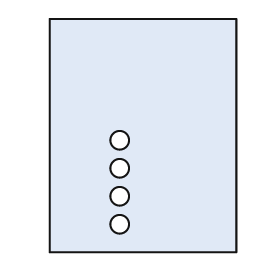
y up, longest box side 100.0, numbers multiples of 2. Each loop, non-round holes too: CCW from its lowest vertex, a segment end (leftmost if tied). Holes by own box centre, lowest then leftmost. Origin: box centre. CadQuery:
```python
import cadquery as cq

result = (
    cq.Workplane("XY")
    .moveTo(-40.0, -50.0)
    .lineTo(40.0, -50.0)
    .lineTo(40.0, 50.0)
    .lineTo(-40.0, 50.0)
    .close()
    .moveTo(-10.0, -38.0)
    .circle(4.0)
    .moveTo(-10.0, -26.0)
    .circle(4.0)
    .moveTo(-10.0, -14.0)
    .circle(4.0)
    .moveTo(-10.0, -2.0)
    .circle(4.0)
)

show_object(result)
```